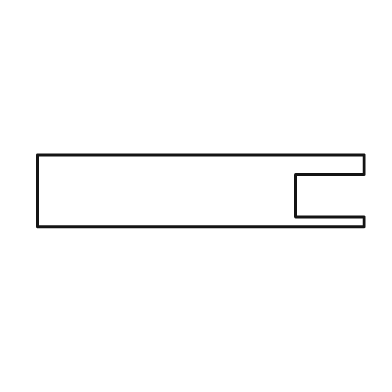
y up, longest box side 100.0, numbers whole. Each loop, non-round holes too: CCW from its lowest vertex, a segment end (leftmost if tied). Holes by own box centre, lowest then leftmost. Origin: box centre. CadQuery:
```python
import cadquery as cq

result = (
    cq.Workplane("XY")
    .moveTo(-50.0, -11.0)
    .lineTo(50.0, -11.0)
    .lineTo(50.0, -8.0)
    .lineTo(29.0, -8.0)
    .lineTo(29.0, 5.0)
    .lineTo(50.0, 5.0)
    .lineTo(50.0, 11.0)
    .lineTo(-50.0, 11.0)
    .close()
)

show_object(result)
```